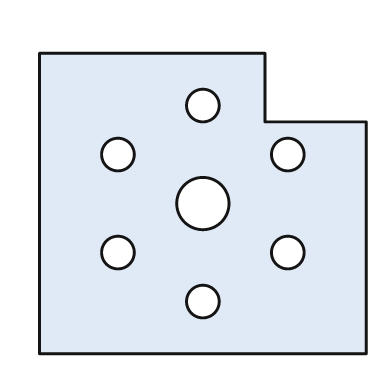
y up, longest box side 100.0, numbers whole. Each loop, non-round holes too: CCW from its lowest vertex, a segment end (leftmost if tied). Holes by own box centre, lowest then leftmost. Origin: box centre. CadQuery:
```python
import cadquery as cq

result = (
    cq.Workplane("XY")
    .moveTo(-50.0, -46.0)
    .lineTo(50.0, -46.0)
    .lineTo(50.0, 25.0)
    .lineTo(19.0, 25.0)
    .lineTo(19.0, 46.0)
    .lineTo(-50.0, 46.0)
    .close()
    .moveTo(0.0, -30.0)
    .circle(5.0)
    .moveTo(-26.0, -15.0)
    .circle(5.0)
    .moveTo(26.0, -15.0)
    .circle(5.0)
    .moveTo(0.0, 0.0)
    .circle(8.0)
    .moveTo(-26.0, 15.0)
    .circle(5.0)
    .moveTo(26.0, 15.0)
    .circle(5.0)
    .moveTo(0.0, 30.0)
    .circle(5.0)
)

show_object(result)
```